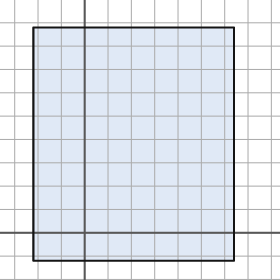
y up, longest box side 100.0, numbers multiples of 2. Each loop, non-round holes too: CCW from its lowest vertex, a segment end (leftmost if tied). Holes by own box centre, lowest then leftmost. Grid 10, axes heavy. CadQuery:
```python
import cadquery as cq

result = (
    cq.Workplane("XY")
    .moveTo(-22.0, -12.0)
    .lineTo(64.0, -12.0)
    .lineTo(64.0, 88.0)
    .lineTo(-22.0, 88.0)
    .close()
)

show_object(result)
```